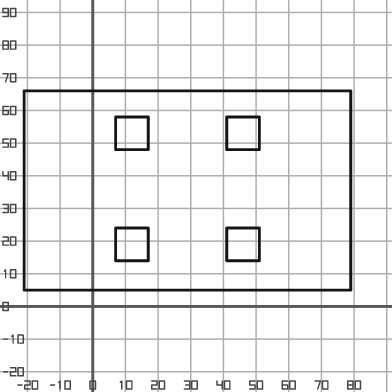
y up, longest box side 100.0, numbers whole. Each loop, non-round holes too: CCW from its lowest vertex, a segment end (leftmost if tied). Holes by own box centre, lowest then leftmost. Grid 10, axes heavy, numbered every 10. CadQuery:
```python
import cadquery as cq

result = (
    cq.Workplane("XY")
    .moveTo(-21.0, 5.0)
    .lineTo(79.0, 5.0)
    .lineTo(79.0, 66.0)
    .lineTo(-21.0, 66.0)
    .close()
    .moveTo(7.0, 14.0)
    .lineTo(17.0, 14.0)
    .lineTo(17.0, 24.0)
    .lineTo(7.0, 24.0)
    .close()
    .moveTo(41.0, 14.0)
    .lineTo(51.0, 14.0)
    .lineTo(51.0, 24.0)
    .lineTo(41.0, 24.0)
    .close()
    .moveTo(7.0, 48.0)
    .lineTo(17.0, 48.0)
    .lineTo(17.0, 58.0)
    .lineTo(7.0, 58.0)
    .close()
    .moveTo(41.0, 48.0)
    .lineTo(51.0, 48.0)
    .lineTo(51.0, 58.0)
    .lineTo(41.0, 58.0)
    .close()
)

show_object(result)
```